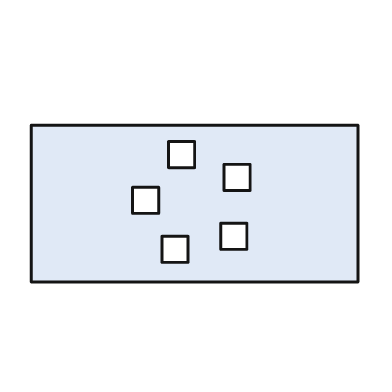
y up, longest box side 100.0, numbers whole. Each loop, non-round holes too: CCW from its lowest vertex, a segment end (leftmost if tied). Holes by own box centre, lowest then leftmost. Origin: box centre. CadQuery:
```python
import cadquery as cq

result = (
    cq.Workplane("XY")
    .moveTo(-50.0, -24.0)
    .lineTo(50.0, -24.0)
    .lineTo(50.0, 24.0)
    .lineTo(-50.0, 24.0)
    .close()
    .moveTo(-10.0, -18.0)
    .lineTo(-2.0, -18.0)
    .lineTo(-2.0, -10.0)
    .lineTo(-10.0, -10.0)
    .close()
    .moveTo(8.0, -14.0)
    .lineTo(16.0, -14.0)
    .lineTo(16.0, -6.0)
    .lineTo(8.0, -6.0)
    .close()
    .moveTo(-19.0, -3.0)
    .lineTo(-11.0, -3.0)
    .lineTo(-11.0, 5.0)
    .lineTo(-19.0, 5.0)
    .close()
    .moveTo(9.0, 4.0)
    .lineTo(17.0, 4.0)
    .lineTo(17.0, 12.0)
    .lineTo(9.0, 12.0)
    .close()
    .moveTo(-8.0, 11.0)
    .lineTo(0.0, 11.0)
    .lineTo(0.0, 19.0)
    .lineTo(-8.0, 19.0)
    .close()
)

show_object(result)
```